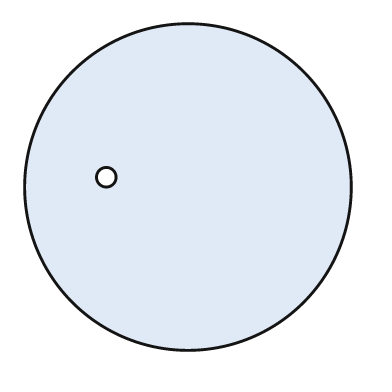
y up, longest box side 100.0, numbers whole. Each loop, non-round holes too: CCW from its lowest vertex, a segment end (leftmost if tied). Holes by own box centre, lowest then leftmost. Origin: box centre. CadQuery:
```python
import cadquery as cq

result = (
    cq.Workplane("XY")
    .moveTo(0.0, 0.0)
    .circle(50.0)
    .moveTo(-25.0, 3.0)
    .circle(3.0)
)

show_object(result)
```